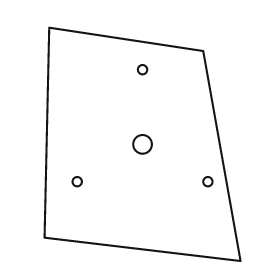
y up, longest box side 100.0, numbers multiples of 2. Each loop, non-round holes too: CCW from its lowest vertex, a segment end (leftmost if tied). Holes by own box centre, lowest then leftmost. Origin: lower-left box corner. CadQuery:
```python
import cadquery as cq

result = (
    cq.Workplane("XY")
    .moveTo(84.0, 0.0)
    .lineTo(68.0, 90.0)
    .lineTo(2.0, 100.0)
    .lineTo(0.0, 10.0)
    .close()
    .moveTo(14.0, 34.0)
    .circle(2.0)
    .moveTo(70.0, 34.0)
    .circle(2.0)
    .moveTo(42.0, 50.0)
    .circle(4.0)
    .moveTo(42.0, 82.0)
    .circle(2.0)
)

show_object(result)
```